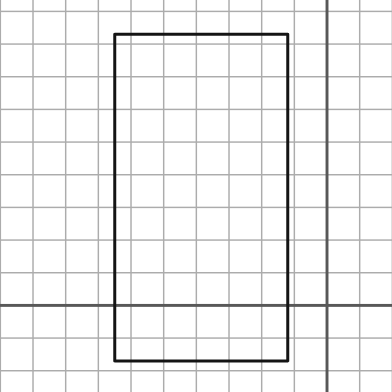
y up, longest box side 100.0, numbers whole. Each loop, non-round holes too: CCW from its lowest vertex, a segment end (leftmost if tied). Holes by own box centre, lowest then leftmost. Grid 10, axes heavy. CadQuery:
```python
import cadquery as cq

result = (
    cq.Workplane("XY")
    .moveTo(-65.0, -17.0)
    .lineTo(-12.0, -17.0)
    .lineTo(-12.0, 83.0)
    .lineTo(-65.0, 83.0)
    .close()
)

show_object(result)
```